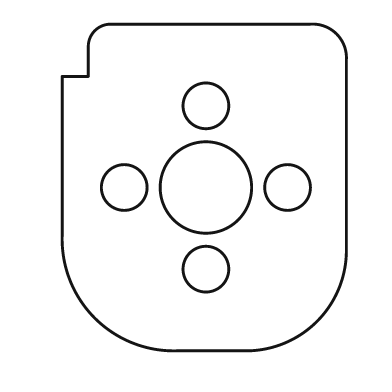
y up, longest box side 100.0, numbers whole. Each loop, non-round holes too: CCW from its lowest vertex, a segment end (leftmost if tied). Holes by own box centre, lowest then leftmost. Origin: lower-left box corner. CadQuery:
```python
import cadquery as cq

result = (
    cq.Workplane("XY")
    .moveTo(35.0, 0.0)
    .lineTo(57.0, 0.0)
    .threePointArc((78.0, 9.0), (87.0, 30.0))
    .lineTo(87.0, 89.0)
    .threePointArc((84.0, 97.0), (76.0, 100.0))
    .lineTo(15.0, 100.0)
    .threePointArc((10.0, 98.0), (8.0, 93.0))
    .lineTo(8.0, 84.0)
    .lineTo(0.0, 84.0)
    .lineTo(0.0, 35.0)
    .threePointArc((10.0, 10.0), (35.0, 0.0))
    .close()
    .moveTo(44.0, 25.0)
    .circle(7.0)
    .moveTo(19.0, 50.0)
    .circle(7.0)
    .moveTo(44.0, 50.0)
    .circle(14.0)
    .moveTo(69.0, 50.0)
    .circle(7.0)
    .moveTo(44.0, 75.0)
    .circle(7.0)
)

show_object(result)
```